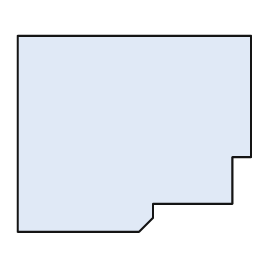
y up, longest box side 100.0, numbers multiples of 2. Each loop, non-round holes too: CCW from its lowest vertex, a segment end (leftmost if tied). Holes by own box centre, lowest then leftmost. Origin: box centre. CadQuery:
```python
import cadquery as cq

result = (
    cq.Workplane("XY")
    .moveTo(-50.0, -42.0)
    .lineTo(2.0, -42.0)
    .lineTo(8.0, -36.0)
    .lineTo(8.0, -30.0)
    .lineTo(42.0, -30.0)
    .lineTo(42.0, -10.0)
    .lineTo(50.0, -10.0)
    .lineTo(50.0, 42.0)
    .lineTo(-50.0, 42.0)
    .close()
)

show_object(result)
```